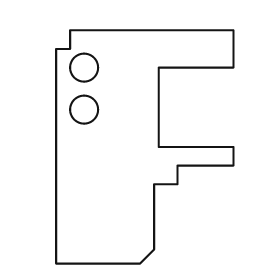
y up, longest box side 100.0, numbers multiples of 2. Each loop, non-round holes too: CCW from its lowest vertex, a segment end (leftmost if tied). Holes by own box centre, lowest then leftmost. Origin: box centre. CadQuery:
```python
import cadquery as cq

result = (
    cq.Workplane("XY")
    .moveTo(-38.0, -50.0)
    .lineTo(-2.0, -50.0)
    .lineTo(4.0, -44.0)
    .lineTo(4.0, -16.0)
    .lineTo(14.0, -16.0)
    .lineTo(14.0, -8.0)
    .lineTo(38.0, -8.0)
    .lineTo(38.0, 0.0)
    .lineTo(6.0, 0.0)
    .lineTo(6.0, 34.0)
    .lineTo(38.0, 34.0)
    .lineTo(38.0, 50.0)
    .lineTo(-32.0, 50.0)
    .lineTo(-32.0, 42.0)
    .lineTo(-38.0, 42.0)
    .close()
    .moveTo(-26.0, 16.0)
    .circle(6.0)
    .moveTo(-26.0, 34.0)
    .circle(6.0)
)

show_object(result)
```